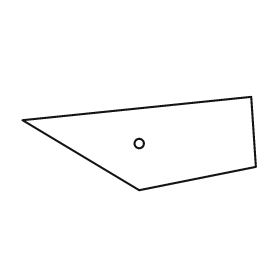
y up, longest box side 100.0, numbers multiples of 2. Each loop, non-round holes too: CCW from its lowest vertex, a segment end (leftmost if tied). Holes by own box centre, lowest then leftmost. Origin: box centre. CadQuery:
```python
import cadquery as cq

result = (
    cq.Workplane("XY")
    .moveTo(0.0, -20.0)
    .lineTo(50.0, -10.0)
    .lineTo(48.0, 20.0)
    .lineTo(-50.0, 10.0)
    .close()
    .moveTo(0.0, 0.0)
    .circle(2.0)
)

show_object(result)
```